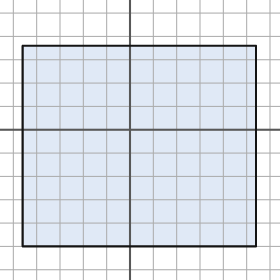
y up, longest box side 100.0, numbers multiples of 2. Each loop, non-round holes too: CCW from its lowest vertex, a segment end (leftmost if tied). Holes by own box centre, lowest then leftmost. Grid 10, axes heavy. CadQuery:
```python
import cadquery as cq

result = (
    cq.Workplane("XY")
    .moveTo(-46.0, -50.0)
    .lineTo(54.0, -50.0)
    .lineTo(54.0, 36.0)
    .lineTo(-46.0, 36.0)
    .close()
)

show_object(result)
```